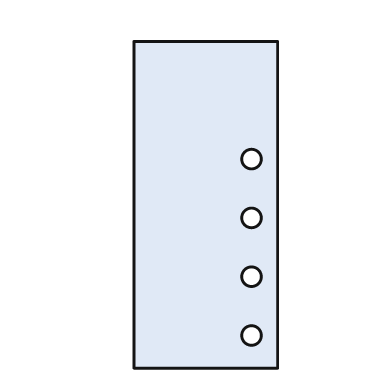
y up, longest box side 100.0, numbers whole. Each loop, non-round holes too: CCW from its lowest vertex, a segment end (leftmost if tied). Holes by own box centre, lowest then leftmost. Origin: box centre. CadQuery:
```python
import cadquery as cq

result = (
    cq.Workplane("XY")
    .moveTo(-22.0, -50.0)
    .lineTo(22.0, -50.0)
    .lineTo(22.0, 50.0)
    .lineTo(-22.0, 50.0)
    .close()
    .moveTo(14.0, -40.0)
    .circle(3.0)
    .moveTo(14.0, -22.0)
    .circle(3.0)
    .moveTo(14.0, -4.0)
    .circle(3.0)
    .moveTo(14.0, 14.0)
    .circle(3.0)
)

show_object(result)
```